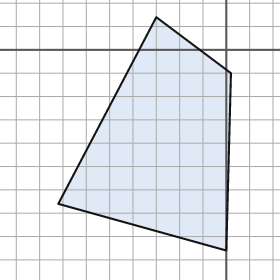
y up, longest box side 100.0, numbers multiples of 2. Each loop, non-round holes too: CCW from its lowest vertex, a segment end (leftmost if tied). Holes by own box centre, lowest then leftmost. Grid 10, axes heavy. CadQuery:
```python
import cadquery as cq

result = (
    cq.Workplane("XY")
    .moveTo(0.0, -86.0)
    .lineTo(2.0, -10.0)
    .lineTo(-30.0, 14.0)
    .lineTo(-72.0, -66.0)
    .close()
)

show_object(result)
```